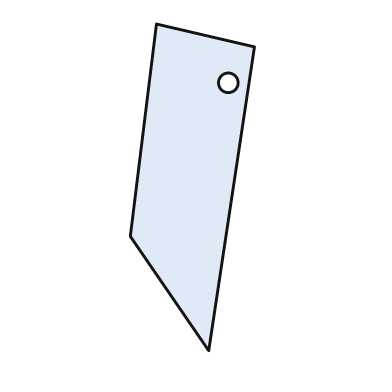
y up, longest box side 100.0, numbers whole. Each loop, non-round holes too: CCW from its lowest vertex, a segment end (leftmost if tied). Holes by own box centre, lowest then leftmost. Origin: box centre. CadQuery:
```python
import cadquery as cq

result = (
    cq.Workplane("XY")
    .moveTo(5.0, -50.0)
    .lineTo(19.0, 43.0)
    .lineTo(-11.0, 50.0)
    .lineTo(-19.0, -15.0)
    .close()
    .moveTo(11.0, 32.0)
    .circle(3.0)
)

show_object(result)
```